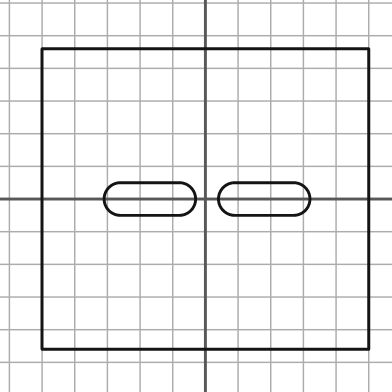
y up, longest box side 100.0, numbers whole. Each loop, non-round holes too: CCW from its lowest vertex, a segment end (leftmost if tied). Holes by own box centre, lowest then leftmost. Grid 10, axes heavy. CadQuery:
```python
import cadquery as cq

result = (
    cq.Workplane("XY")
    .moveTo(-50.0, -46.0)
    .lineTo(50.0, -46.0)
    .lineTo(50.0, 46.0)
    .lineTo(-50.0, 46.0)
    .close()
    .moveTo(-26.0, -5.0)
    .lineTo(-8.0, -5.0)
    .threePointArc((-3.0, 0.0), (-8.0, 5.0))
    .lineTo(-26.0, 5.0)
    .threePointArc((-31.0, 0.0), (-26.0, -5.0))
    .close()
    .moveTo(9.0, -5.0)
    .lineTo(27.0, -5.0)
    .threePointArc((32.0, 0.0), (27.0, 5.0))
    .lineTo(9.0, 5.0)
    .threePointArc((4.0, 0.0), (9.0, -5.0))
    .close()
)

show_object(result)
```